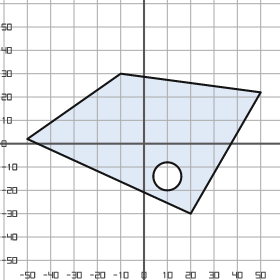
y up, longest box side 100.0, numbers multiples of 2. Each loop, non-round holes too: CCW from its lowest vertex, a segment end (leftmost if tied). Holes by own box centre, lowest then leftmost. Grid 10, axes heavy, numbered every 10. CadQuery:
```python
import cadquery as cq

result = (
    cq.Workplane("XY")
    .moveTo(20.0, -30.0)
    .lineTo(50.0, 22.0)
    .lineTo(-10.0, 30.0)
    .lineTo(-50.0, 2.0)
    .close()
    .moveTo(10.0, -14.0)
    .circle(6.0)
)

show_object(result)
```